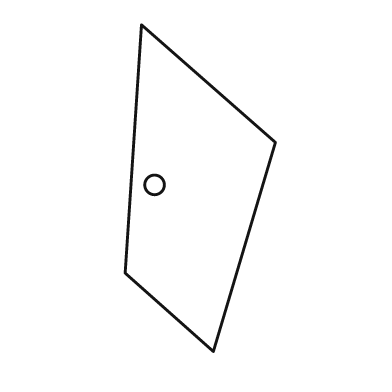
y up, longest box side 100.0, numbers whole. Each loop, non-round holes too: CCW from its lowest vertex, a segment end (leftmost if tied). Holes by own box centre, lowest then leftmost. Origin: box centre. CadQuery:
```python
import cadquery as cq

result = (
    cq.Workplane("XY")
    .moveTo(4.0, -50.0)
    .lineTo(23.0, 14.0)
    .lineTo(-18.0, 50.0)
    .lineTo(-23.0, -26.0)
    .close()
    .moveTo(-14.0, 1.0)
    .circle(3.0)
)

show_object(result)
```